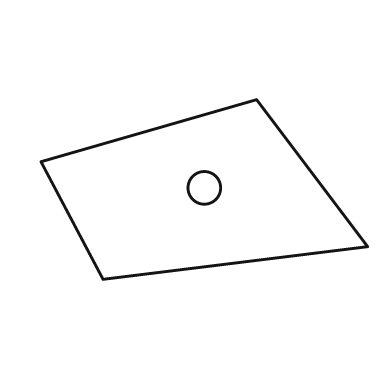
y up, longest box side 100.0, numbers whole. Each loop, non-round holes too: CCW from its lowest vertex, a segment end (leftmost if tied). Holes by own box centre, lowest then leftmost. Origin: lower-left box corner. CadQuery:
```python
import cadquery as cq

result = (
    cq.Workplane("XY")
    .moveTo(19.0, 0.0)
    .lineTo(100.0, 10.0)
    .lineTo(66.0, 55.0)
    .lineTo(0.0, 36.0)
    .close()
    .moveTo(50.0, 28.0)
    .circle(5.0)
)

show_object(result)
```